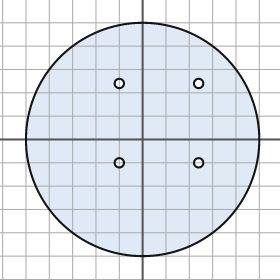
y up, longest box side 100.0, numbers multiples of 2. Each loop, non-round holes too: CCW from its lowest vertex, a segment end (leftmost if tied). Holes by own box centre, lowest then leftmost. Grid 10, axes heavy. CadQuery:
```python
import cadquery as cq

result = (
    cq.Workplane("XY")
    .moveTo(0.0, 0.0)
    .circle(50.0)
    .moveTo(-10.0, -10.0)
    .circle(2.0)
    .moveTo(24.0, -10.0)
    .circle(2.0)
    .moveTo(-10.0, 24.0)
    .circle(2.0)
    .moveTo(24.0, 24.0)
    .circle(2.0)
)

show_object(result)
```